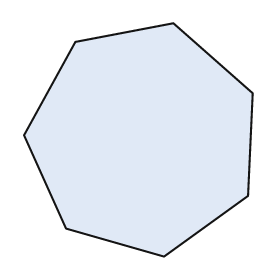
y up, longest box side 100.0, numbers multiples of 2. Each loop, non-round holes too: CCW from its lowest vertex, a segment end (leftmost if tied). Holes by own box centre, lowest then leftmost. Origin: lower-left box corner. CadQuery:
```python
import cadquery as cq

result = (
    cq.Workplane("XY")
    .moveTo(60.0, 0.0)
    .lineTo(96.0, 26.0)
    .lineTo(98.0, 70.0)
    .lineTo(64.0, 100.0)
    .lineTo(22.0, 92.0)
    .lineTo(0.0, 52.0)
    .lineTo(18.0, 12.0)
    .close()
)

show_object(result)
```